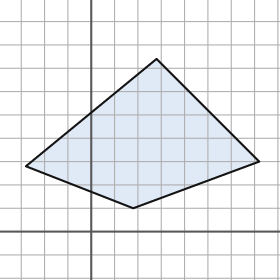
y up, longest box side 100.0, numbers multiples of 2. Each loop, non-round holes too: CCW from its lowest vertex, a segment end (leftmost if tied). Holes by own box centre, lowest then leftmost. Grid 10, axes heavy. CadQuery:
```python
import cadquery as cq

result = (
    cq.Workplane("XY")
    .moveTo(18.0, 10.0)
    .lineTo(72.0, 30.0)
    .lineTo(28.0, 74.0)
    .lineTo(-28.0, 28.0)
    .close()
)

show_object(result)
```